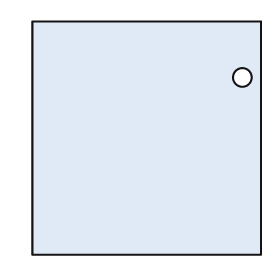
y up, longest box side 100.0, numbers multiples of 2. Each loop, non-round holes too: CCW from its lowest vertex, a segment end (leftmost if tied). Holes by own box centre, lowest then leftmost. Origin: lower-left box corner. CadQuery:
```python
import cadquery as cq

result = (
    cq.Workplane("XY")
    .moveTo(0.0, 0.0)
    .lineTo(98.0, 0.0)
    .lineTo(98.0, 100.0)
    .lineTo(0.0, 100.0)
    .close()
    .moveTo(90.0, 76.0)
    .circle(4.0)
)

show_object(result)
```